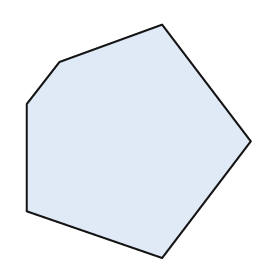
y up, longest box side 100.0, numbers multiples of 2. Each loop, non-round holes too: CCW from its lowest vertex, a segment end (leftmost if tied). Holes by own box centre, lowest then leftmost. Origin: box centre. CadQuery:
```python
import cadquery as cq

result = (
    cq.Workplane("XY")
    .moveTo(10.0, -50.0)
    .lineTo(48.0, 0.0)
    .lineTo(10.0, 50.0)
    .lineTo(-34.0, 34.0)
    .lineTo(-48.0, 16.0)
    .lineTo(-48.0, -30.0)
    .close()
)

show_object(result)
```